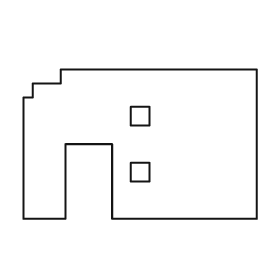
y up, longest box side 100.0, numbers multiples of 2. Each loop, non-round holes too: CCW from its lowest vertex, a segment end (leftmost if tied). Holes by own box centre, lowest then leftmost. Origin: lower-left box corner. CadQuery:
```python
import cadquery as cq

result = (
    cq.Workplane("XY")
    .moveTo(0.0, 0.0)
    .lineTo(18.0, 0.0)
    .lineTo(18.0, 32.0)
    .lineTo(38.0, 32.0)
    .lineTo(38.0, 0.0)
    .lineTo(100.0, 0.0)
    .lineTo(100.0, 64.0)
    .lineTo(16.0, 64.0)
    .lineTo(16.0, 58.0)
    .lineTo(4.0, 58.0)
    .lineTo(4.0, 52.0)
    .lineTo(0.0, 52.0)
    .close()
    .moveTo(46.0, 16.0)
    .lineTo(54.0, 16.0)
    .lineTo(54.0, 24.0)
    .lineTo(46.0, 24.0)
    .close()
    .moveTo(46.0, 40.0)
    .lineTo(54.0, 40.0)
    .lineTo(54.0, 48.0)
    .lineTo(46.0, 48.0)
    .close()
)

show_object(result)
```